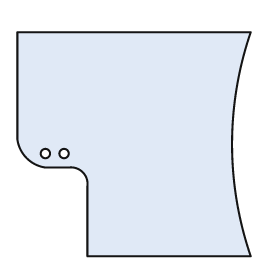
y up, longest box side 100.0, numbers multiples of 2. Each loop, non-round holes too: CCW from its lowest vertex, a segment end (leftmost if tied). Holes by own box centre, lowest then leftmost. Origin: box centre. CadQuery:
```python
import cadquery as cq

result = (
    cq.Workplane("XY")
    .moveTo(-20.0, -48.0)
    .lineTo(50.0, -48.0)
    .threePointArc((42.0, 0.0), (50.0, 48.0))
    .lineTo(-50.0, 48.0)
    .lineTo(-50.0, 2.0)
    .threePointArc((-46.0, -6.0), (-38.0, -10.0))
    .lineTo(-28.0, -10.0)
    .threePointArc((-22.0, -12.0), (-20.0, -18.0))
    .close()
    .moveTo(-38.0, -4.0)
    .circle(2.0)
    .moveTo(-30.0, -4.0)
    .circle(2.0)
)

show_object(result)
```